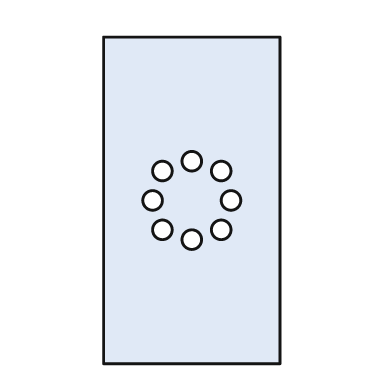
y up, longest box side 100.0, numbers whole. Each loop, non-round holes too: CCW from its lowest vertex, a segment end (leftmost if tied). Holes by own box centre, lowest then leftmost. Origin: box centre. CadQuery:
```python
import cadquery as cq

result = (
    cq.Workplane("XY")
    .moveTo(-27.0, -50.0)
    .lineTo(27.0, -50.0)
    .lineTo(27.0, 50.0)
    .lineTo(-27.0, 50.0)
    .close()
    .moveTo(0.0, -12.0)
    .circle(3.0)
    .moveTo(-9.0, -9.0)
    .circle(3.0)
    .moveTo(9.0, -9.0)
    .circle(3.0)
    .moveTo(-12.0, 0.0)
    .circle(3.0)
    .moveTo(12.0, 0.0)
    .circle(3.0)
    .moveTo(-9.0, 9.0)
    .circle(3.0)
    .moveTo(9.0, 9.0)
    .circle(3.0)
    .moveTo(0.0, 12.0)
    .circle(3.0)
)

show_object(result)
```